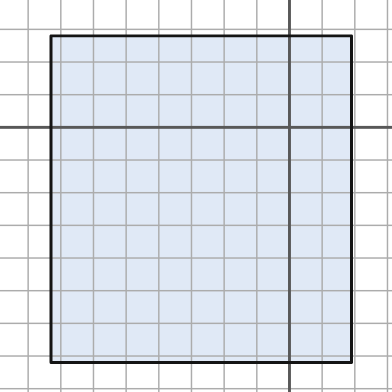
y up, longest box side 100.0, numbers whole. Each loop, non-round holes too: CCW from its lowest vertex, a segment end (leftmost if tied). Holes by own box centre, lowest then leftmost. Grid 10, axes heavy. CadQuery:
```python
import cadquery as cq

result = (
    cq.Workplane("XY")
    .moveTo(-73.0, -72.0)
    .lineTo(19.0, -72.0)
    .lineTo(19.0, 28.0)
    .lineTo(-73.0, 28.0)
    .close()
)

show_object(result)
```